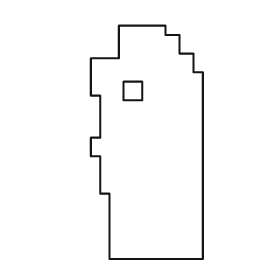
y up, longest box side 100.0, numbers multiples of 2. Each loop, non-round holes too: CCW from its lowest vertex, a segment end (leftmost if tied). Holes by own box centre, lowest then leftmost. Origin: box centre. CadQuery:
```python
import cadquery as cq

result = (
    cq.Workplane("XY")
    .moveTo(-16.0, -50.0)
    .lineTo(24.0, -50.0)
    .lineTo(24.0, 30.0)
    .lineTo(20.0, 30.0)
    .lineTo(20.0, 38.0)
    .lineTo(14.0, 38.0)
    .lineTo(14.0, 46.0)
    .lineTo(8.0, 46.0)
    .lineTo(8.0, 50.0)
    .lineTo(-12.0, 50.0)
    .lineTo(-12.0, 36.0)
    .lineTo(-24.0, 36.0)
    .lineTo(-24.0, 20.0)
    .lineTo(-20.0, 20.0)
    .lineTo(-20.0, 2.0)
    .lineTo(-24.0, 2.0)
    .lineTo(-24.0, -6.0)
    .lineTo(-20.0, -6.0)
    .lineTo(-20.0, -22.0)
    .lineTo(-16.0, -22.0)
    .close()
    .moveTo(-10.0, 18.0)
    .lineTo(-2.0, 18.0)
    .lineTo(-2.0, 26.0)
    .lineTo(-10.0, 26.0)
    .close()
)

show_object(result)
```